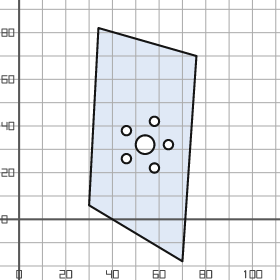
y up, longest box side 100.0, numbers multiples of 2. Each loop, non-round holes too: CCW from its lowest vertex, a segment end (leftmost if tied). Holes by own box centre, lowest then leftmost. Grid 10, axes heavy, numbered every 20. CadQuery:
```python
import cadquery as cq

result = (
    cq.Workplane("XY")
    .moveTo(70.0, -18.0)
    .lineTo(76.0, 70.0)
    .lineTo(34.0, 82.0)
    .lineTo(30.0, 6.0)
    .close()
    .moveTo(58.0, 22.0)
    .circle(2.0)
    .moveTo(46.0, 26.0)
    .circle(2.0)
    .moveTo(54.0, 32.0)
    .circle(4.0)
    .moveTo(64.0, 32.0)
    .circle(2.0)
    .moveTo(46.0, 38.0)
    .circle(2.0)
    .moveTo(58.0, 42.0)
    .circle(2.0)
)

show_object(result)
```